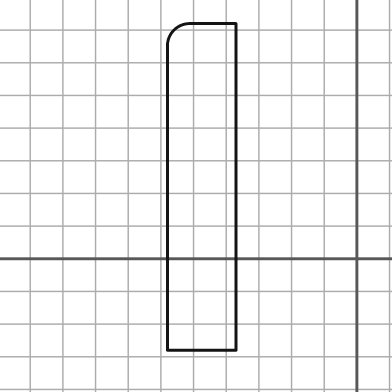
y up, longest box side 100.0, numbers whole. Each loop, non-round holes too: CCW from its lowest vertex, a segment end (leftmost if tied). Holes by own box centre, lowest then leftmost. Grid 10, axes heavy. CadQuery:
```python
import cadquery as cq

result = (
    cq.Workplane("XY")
    .moveTo(-58.0, -28.0)
    .lineTo(-37.0, -28.0)
    .lineTo(-37.0, 72.0)
    .lineTo(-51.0, 72.0)
    .threePointArc((-56.0, 70.0), (-58.0, 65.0))
    .close()
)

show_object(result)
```